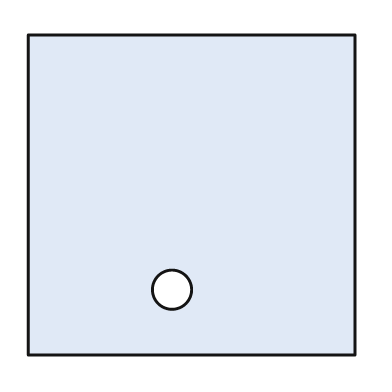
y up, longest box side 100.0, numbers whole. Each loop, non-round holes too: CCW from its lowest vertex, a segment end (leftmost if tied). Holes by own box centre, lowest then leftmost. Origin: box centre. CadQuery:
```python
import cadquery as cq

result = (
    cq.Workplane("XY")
    .moveTo(-50.0, -49.0)
    .lineTo(50.0, -49.0)
    .lineTo(50.0, 49.0)
    .lineTo(-50.0, 49.0)
    .close()
    .moveTo(-6.0, -29.0)
    .circle(6.0)
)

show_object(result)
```